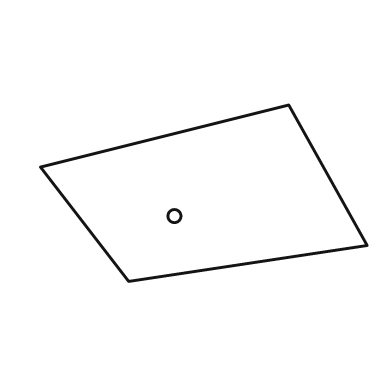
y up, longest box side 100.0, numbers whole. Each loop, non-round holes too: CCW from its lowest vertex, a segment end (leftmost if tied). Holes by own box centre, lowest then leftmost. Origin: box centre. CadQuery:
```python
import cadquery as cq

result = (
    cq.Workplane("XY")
    .moveTo(-23.0, -27.0)
    .lineTo(50.0, -16.0)
    .lineTo(26.0, 27.0)
    .lineTo(-50.0, 8.0)
    .close()
    .moveTo(-9.0, -7.0)
    .circle(2.0)
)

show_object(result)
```